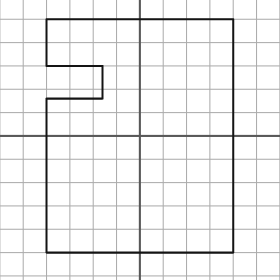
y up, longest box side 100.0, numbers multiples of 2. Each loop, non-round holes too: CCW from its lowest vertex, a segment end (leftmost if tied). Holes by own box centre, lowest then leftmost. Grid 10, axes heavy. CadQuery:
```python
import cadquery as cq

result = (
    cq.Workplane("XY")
    .moveTo(-40.0, -50.0)
    .lineTo(40.0, -50.0)
    .lineTo(40.0, 50.0)
    .lineTo(-40.0, 50.0)
    .lineTo(-40.0, 30.0)
    .lineTo(-16.0, 30.0)
    .lineTo(-16.0, 16.0)
    .lineTo(-40.0, 16.0)
    .close()
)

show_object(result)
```